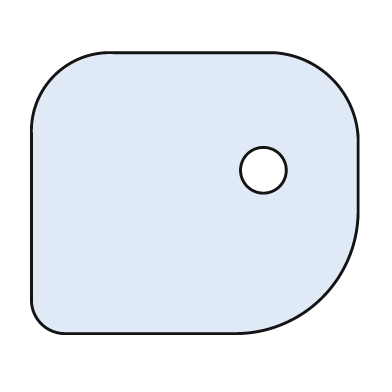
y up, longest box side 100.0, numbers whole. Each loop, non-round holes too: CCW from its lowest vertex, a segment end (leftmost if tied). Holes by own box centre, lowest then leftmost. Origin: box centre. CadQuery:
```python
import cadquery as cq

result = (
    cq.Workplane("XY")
    .moveTo(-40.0, -43.0)
    .lineTo(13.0, -43.0)
    .threePointArc((39.0, -32.0), (50.0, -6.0))
    .lineTo(50.0, 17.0)
    .threePointArc((42.0, 35.0), (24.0, 43.0))
    .lineTo(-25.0, 43.0)
    .threePointArc((-43.0, 36.0), (-50.0, 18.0))
    .lineTo(-50.0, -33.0)
    .threePointArc((-47.0, -40.0), (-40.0, -43.0))
    .close()
    .moveTo(21.0, 7.0)
    .circle(7.0)
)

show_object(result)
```